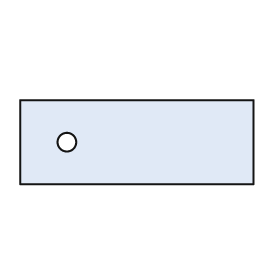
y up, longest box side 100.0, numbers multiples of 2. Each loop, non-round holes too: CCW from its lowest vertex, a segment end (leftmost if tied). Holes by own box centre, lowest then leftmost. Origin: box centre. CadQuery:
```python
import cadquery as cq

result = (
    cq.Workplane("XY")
    .moveTo(-50.0, -18.0)
    .lineTo(50.0, -18.0)
    .lineTo(50.0, 18.0)
    .lineTo(-50.0, 18.0)
    .close()
    .moveTo(-30.0, 0.0)
    .circle(4.0)
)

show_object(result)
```